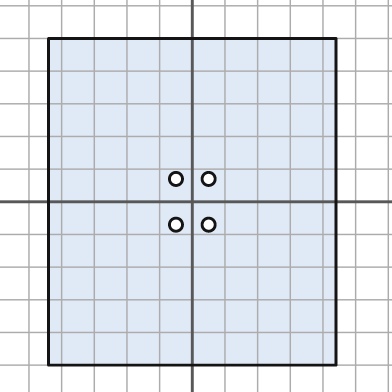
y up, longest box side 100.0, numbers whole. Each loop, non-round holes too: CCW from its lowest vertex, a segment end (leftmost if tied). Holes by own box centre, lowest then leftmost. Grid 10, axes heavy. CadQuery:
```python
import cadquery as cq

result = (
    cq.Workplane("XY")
    .moveTo(-44.0, -50.0)
    .lineTo(44.0, -50.0)
    .lineTo(44.0, 50.0)
    .lineTo(-44.0, 50.0)
    .close()
    .moveTo(-5.0, -7.0)
    .circle(2.0)
    .moveTo(5.0, -7.0)
    .circle(2.0)
    .moveTo(-5.0, 7.0)
    .circle(2.0)
    .moveTo(5.0, 7.0)
    .circle(2.0)
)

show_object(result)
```